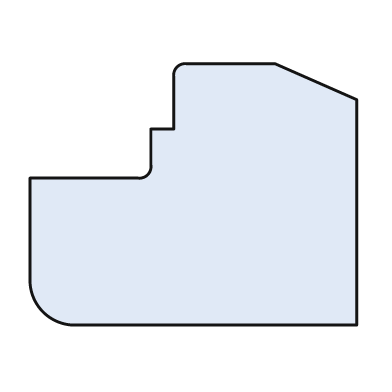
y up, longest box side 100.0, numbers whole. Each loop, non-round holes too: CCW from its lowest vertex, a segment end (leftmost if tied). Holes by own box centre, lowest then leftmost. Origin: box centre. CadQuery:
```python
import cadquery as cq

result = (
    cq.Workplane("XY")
    .moveTo(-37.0, -40.0)
    .lineTo(50.0, -40.0)
    .lineTo(50.0, 29.0)
    .lineTo(25.0, 40.0)
    .lineTo(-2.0, 40.0)
    .threePointArc((-5.0, 39.0), (-6.0, 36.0))
    .lineTo(-6.0, 20.0)
    .lineTo(-13.0, 20.0)
    .lineTo(-13.0, 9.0)
    .threePointArc((-14.0, 6.0), (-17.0, 5.0))
    .lineTo(-50.0, 5.0)
    .lineTo(-50.0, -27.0)
    .threePointArc((-46.0, -36.0), (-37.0, -40.0))
    .close()
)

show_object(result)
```